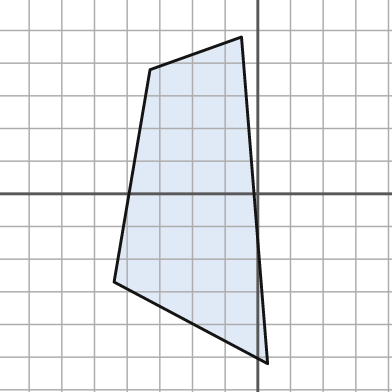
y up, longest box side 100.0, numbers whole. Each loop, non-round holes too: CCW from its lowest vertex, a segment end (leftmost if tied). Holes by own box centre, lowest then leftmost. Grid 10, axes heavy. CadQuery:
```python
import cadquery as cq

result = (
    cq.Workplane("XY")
    .moveTo(3.0, -52.0)
    .lineTo(-5.0, 48.0)
    .lineTo(-33.0, 38.0)
    .lineTo(-44.0, -27.0)
    .close()
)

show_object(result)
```